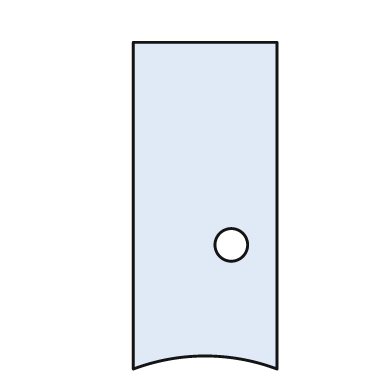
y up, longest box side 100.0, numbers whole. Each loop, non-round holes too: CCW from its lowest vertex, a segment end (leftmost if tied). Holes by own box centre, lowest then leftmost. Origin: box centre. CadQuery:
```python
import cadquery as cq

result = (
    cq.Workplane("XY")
    .moveTo(-22.0, -50.0)
    .threePointArc((0.0, -46.0), (22.0, -50.0))
    .lineTo(22.0, 50.0)
    .lineTo(-22.0, 50.0)
    .close()
    .moveTo(8.0, -12.0)
    .circle(5.0)
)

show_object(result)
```